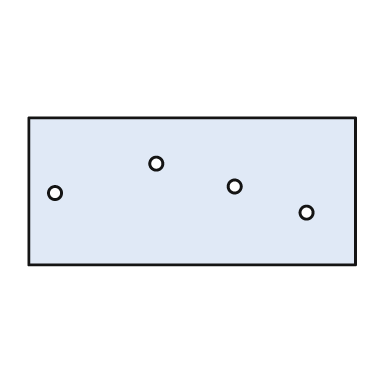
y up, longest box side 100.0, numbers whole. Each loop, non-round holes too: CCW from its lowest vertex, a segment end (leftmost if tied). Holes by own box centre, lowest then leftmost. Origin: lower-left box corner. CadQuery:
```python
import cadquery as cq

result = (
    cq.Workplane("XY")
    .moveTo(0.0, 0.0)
    .lineTo(100.0, 0.0)
    .lineTo(100.0, 45.0)
    .lineTo(0.0, 45.0)
    .close()
    .moveTo(85.0, 16.0)
    .circle(2.0)
    .moveTo(8.0, 22.0)
    .circle(2.0)
    .moveTo(63.0, 24.0)
    .circle(2.0)
    .moveTo(39.0, 31.0)
    .circle(2.0)
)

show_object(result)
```